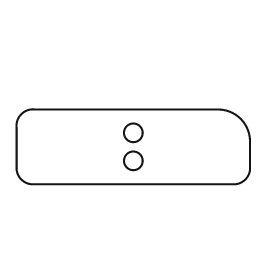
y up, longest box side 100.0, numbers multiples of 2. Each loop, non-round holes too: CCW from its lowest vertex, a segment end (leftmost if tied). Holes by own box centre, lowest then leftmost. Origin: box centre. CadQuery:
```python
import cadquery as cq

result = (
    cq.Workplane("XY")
    .moveTo(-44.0, -16.0)
    .lineTo(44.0, -16.0)
    .threePointArc((48.0, -14.0), (50.0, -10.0))
    .lineTo(50.0, 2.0)
    .threePointArc((46.0, 12.0), (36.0, 16.0))
    .lineTo(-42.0, 16.0)
    .threePointArc((-48.0, 14.0), (-50.0, 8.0))
    .lineTo(-50.0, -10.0)
    .threePointArc((-48.0, -14.0), (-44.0, -16.0))
    .close()
    .moveTo(0.0, -6.0)
    .circle(4.0)
    .moveTo(0.0, 6.0)
    .circle(4.0)
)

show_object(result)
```